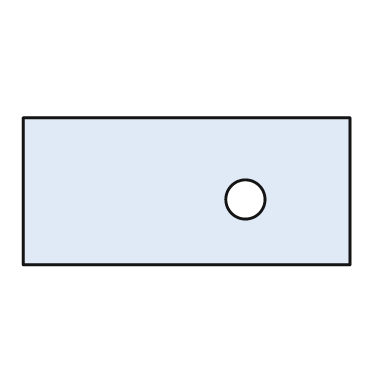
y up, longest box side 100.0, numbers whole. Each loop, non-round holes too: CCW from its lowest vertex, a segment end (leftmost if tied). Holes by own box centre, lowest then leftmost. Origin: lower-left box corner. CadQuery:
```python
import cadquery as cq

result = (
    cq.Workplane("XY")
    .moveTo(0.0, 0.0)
    .lineTo(100.0, 0.0)
    .lineTo(100.0, 45.0)
    .lineTo(0.0, 45.0)
    .close()
    .moveTo(68.0, 20.0)
    .circle(6.0)
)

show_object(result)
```